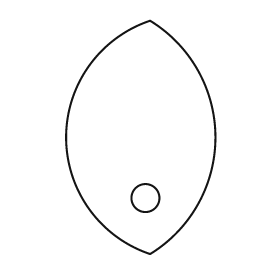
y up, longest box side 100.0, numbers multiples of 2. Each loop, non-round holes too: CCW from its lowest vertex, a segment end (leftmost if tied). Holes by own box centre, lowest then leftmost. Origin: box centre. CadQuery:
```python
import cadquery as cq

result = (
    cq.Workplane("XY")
    .moveTo(4.0, -50.0)
    .threePointArc((32.0, 0.0), (4.0, 50.0))
    .threePointArc((-32.0, 0.0), (4.0, -50.0))
    .close()
    .moveTo(2.0, -26.0)
    .circle(6.0)
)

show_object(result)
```